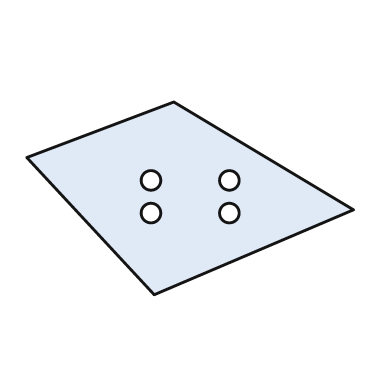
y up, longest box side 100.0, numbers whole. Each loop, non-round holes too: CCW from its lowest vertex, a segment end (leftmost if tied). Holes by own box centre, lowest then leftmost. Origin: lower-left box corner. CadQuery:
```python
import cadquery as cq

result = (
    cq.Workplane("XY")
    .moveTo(39.0, 0.0)
    .lineTo(100.0, 26.0)
    .lineTo(45.0, 59.0)
    .lineTo(0.0, 42.0)
    .close()
    .moveTo(38.0, 25.0)
    .circle(3.0)
    .moveTo(62.0, 25.0)
    .circle(3.0)
    .moveTo(38.0, 35.0)
    .circle(3.0)
    .moveTo(62.0, 35.0)
    .circle(3.0)
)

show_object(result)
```